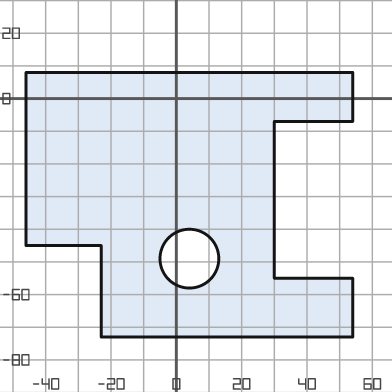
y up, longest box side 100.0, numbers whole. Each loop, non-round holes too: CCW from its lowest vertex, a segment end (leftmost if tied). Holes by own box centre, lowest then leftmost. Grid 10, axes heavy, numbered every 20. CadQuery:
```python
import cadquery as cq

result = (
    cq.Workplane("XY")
    .moveTo(-23.0, -73.0)
    .lineTo(54.0, -73.0)
    .lineTo(54.0, -55.0)
    .lineTo(30.0, -55.0)
    .lineTo(30.0, -7.0)
    .lineTo(54.0, -7.0)
    .lineTo(54.0, 8.0)
    .lineTo(-46.0, 8.0)
    .lineTo(-46.0, -45.0)
    .lineTo(-23.0, -45.0)
    .close()
    .moveTo(4.0, -49.0)
    .circle(9.0)
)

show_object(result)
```